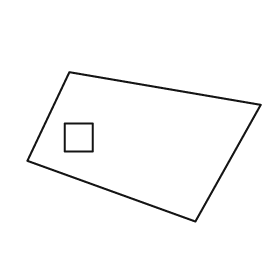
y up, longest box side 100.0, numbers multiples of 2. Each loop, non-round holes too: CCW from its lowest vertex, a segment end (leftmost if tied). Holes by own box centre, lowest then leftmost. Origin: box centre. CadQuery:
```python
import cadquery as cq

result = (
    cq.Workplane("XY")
    .moveTo(22.0, -32.0)
    .lineTo(50.0, 18.0)
    .lineTo(-32.0, 32.0)
    .lineTo(-50.0, -6.0)
    .close()
    .moveTo(-34.0, -2.0)
    .lineTo(-22.0, -2.0)
    .lineTo(-22.0, 10.0)
    .lineTo(-34.0, 10.0)
    .close()
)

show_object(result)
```